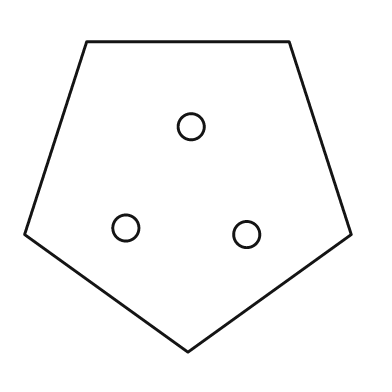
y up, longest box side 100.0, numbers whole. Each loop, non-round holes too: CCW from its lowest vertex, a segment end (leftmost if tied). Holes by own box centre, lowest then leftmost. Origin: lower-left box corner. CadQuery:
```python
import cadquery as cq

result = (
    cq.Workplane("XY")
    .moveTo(50.0, 0.0)
    .lineTo(100.0, 36.0)
    .lineTo(81.0, 95.0)
    .lineTo(19.0, 95.0)
    .lineTo(0.0, 36.0)
    .close()
    .moveTo(68.0, 36.0)
    .circle(4.0)
    .moveTo(31.0, 38.0)
    .circle(4.0)
    .moveTo(51.0, 69.0)
    .circle(4.0)
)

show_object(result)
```